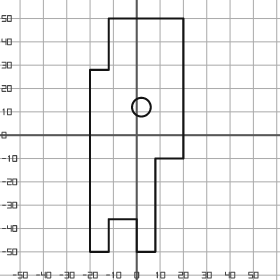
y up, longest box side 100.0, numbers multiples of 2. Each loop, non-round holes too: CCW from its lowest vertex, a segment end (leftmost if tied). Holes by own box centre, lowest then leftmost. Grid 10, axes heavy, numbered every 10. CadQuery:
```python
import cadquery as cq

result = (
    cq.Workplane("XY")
    .moveTo(-20.0, -50.0)
    .lineTo(-12.0, -50.0)
    .lineTo(-12.0, -36.0)
    .lineTo(0.0, -36.0)
    .lineTo(0.0, -50.0)
    .lineTo(8.0, -50.0)
    .lineTo(8.0, -10.0)
    .lineTo(20.0, -10.0)
    .lineTo(20.0, 50.0)
    .lineTo(-12.0, 50.0)
    .lineTo(-12.0, 28.0)
    .lineTo(-20.0, 28.0)
    .close()
    .moveTo(2.0, 12.0)
    .circle(4.0)
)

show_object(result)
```